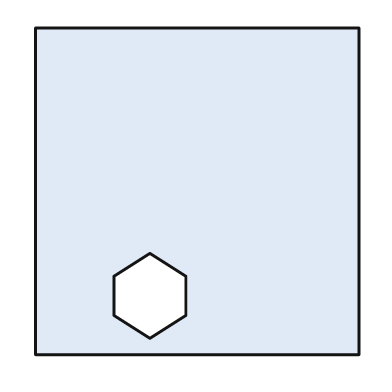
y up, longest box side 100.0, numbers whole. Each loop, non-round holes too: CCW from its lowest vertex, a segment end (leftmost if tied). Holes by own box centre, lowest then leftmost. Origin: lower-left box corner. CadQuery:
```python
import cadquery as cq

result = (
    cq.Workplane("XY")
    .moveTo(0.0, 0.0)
    .lineTo(99.0, 0.0)
    .lineTo(99.0, 100.0)
    .lineTo(0.0, 100.0)
    .close()
    .moveTo(35.0, 5.0)
    .lineTo(46.0, 12.0)
    .lineTo(46.0, 24.0)
    .lineTo(35.0, 31.0)
    .lineTo(24.0, 24.0)
    .lineTo(24.0, 12.0)
    .close()
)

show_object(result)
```